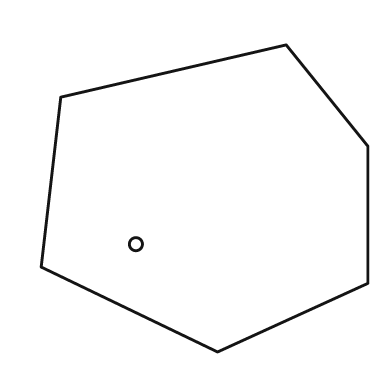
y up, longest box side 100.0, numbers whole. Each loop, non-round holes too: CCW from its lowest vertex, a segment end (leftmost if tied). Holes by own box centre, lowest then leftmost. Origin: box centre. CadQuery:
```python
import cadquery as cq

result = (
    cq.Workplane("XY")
    .moveTo(4.0, -47.0)
    .lineTo(50.0, -26.0)
    .lineTo(50.0, 16.0)
    .lineTo(25.0, 47.0)
    .lineTo(-44.0, 31.0)
    .lineTo(-50.0, -21.0)
    .close()
    .moveTo(-21.0, -14.0)
    .circle(2.0)
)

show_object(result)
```